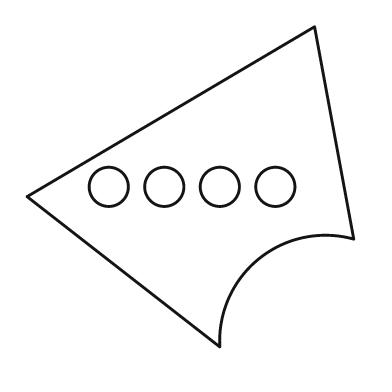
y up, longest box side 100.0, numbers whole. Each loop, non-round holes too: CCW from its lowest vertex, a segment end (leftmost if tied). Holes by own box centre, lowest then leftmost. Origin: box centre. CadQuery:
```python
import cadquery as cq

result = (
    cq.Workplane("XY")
    .moveTo(9.0, -49.0)
    .threePointArc((21.0, -22.0), (50.0, -16.0))
    .lineTo(38.0, 49.0)
    .lineTo(-50.0, -3.0)
    .close()
    .moveTo(-25.0, 0.0)
    .circle(6.0)
    .moveTo(-8.0, 0.0)
    .circle(6.0)
    .moveTo(9.0, 0.0)
    .circle(6.0)
    .moveTo(26.0, 0.0)
    .circle(6.0)
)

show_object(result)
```